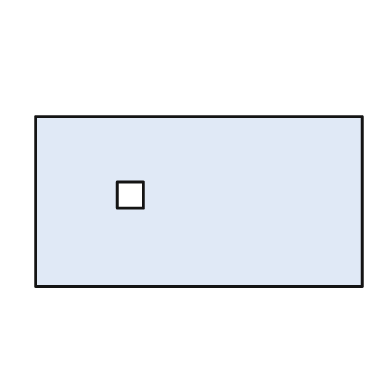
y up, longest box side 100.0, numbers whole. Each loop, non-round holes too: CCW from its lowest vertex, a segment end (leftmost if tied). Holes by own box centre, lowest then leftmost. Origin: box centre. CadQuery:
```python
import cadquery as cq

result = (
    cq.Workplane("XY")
    .moveTo(-50.0, -26.0)
    .lineTo(50.0, -26.0)
    .lineTo(50.0, 26.0)
    .lineTo(-50.0, 26.0)
    .close()
    .moveTo(-25.0, -2.0)
    .lineTo(-17.0, -2.0)
    .lineTo(-17.0, 6.0)
    .lineTo(-25.0, 6.0)
    .close()
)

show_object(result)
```